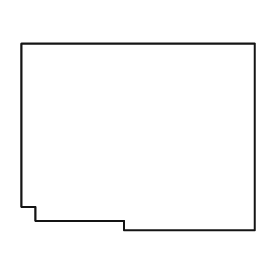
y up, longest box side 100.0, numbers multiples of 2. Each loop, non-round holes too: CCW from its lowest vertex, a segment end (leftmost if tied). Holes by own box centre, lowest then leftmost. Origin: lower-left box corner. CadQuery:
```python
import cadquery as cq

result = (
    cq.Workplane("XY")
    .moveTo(44.0, 0.0)
    .lineTo(100.0, 0.0)
    .lineTo(100.0, 80.0)
    .lineTo(0.0, 80.0)
    .lineTo(0.0, 10.0)
    .lineTo(6.0, 10.0)
    .lineTo(6.0, 4.0)
    .lineTo(44.0, 4.0)
    .close()
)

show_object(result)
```